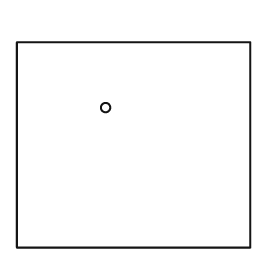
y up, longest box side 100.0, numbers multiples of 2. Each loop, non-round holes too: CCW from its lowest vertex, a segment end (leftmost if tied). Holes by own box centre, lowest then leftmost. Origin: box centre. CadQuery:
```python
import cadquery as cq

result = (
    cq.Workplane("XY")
    .moveTo(-50.0, -44.0)
    .lineTo(50.0, -44.0)
    .lineTo(50.0, 44.0)
    .lineTo(-50.0, 44.0)
    .close()
    .moveTo(-12.0, 16.0)
    .circle(2.0)
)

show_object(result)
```